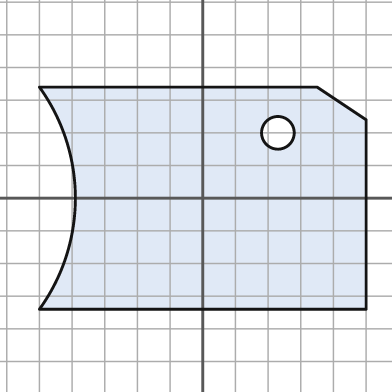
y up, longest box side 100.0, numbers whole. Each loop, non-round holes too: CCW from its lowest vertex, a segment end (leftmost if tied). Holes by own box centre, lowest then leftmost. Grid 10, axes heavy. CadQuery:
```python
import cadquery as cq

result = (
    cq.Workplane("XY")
    .moveTo(-50.0, -34.0)
    .lineTo(50.0, -34.0)
    .lineTo(50.0, 24.0)
    .lineTo(35.0, 34.0)
    .lineTo(-50.0, 34.0)
    .threePointArc((-39.0, 0.0), (-50.0, -34.0))
    .close()
    .moveTo(23.0, 20.0)
    .circle(5.0)
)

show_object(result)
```